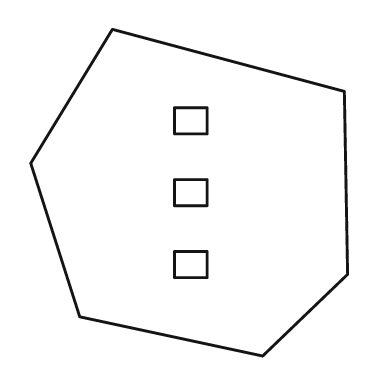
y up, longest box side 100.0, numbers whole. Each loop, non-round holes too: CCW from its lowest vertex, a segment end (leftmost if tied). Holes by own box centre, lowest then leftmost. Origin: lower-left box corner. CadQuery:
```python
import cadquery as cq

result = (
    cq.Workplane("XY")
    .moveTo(71.0, 0.0)
    .lineTo(97.0, 25.0)
    .lineTo(96.0, 81.0)
    .lineTo(25.0, 100.0)
    .lineTo(0.0, 59.0)
    .lineTo(15.0, 12.0)
    .close()
    .moveTo(44.0, 24.0)
    .lineTo(54.0, 24.0)
    .lineTo(54.0, 32.0)
    .lineTo(44.0, 32.0)
    .close()
    .moveTo(44.0, 46.0)
    .lineTo(54.0, 46.0)
    .lineTo(54.0, 54.0)
    .lineTo(44.0, 54.0)
    .close()
    .moveTo(44.0, 68.0)
    .lineTo(54.0, 68.0)
    .lineTo(54.0, 76.0)
    .lineTo(44.0, 76.0)
    .close()
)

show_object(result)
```